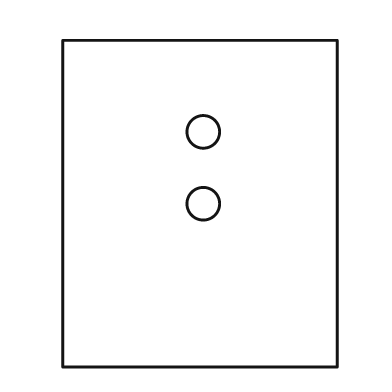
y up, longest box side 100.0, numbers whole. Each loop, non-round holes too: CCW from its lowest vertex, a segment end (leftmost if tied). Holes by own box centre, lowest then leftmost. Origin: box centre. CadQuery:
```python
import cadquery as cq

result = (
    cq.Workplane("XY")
    .moveTo(-42.0, -50.0)
    .lineTo(42.0, -50.0)
    .lineTo(42.0, 50.0)
    .lineTo(-42.0, 50.0)
    .close()
    .moveTo(1.0, 0.0)
    .circle(5.0)
    .moveTo(1.0, 22.0)
    .circle(5.0)
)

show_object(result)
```